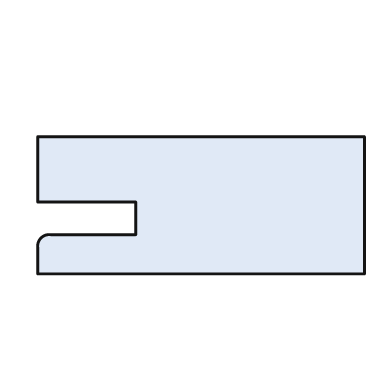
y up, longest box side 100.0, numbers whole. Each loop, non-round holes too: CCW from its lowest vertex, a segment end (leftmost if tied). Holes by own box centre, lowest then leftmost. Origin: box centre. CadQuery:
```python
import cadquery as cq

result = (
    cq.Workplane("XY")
    .moveTo(-50.0, -21.0)
    .lineTo(50.0, -21.0)
    .lineTo(50.0, 21.0)
    .lineTo(-50.0, 21.0)
    .lineTo(-50.0, 1.0)
    .lineTo(-20.0, 1.0)
    .lineTo(-20.0, -9.0)
    .lineTo(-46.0, -9.0)
    .threePointArc((-49.0, -10.0), (-50.0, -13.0))
    .close()
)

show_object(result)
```